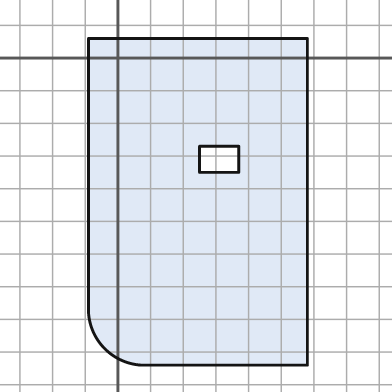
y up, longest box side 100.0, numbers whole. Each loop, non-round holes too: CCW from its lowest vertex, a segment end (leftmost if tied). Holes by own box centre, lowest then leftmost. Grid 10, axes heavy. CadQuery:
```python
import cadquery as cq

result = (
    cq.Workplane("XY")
    .moveTo(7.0, -94.0)
    .lineTo(58.0, -94.0)
    .lineTo(58.0, 6.0)
    .lineTo(-9.0, 6.0)
    .lineTo(-9.0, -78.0)
    .threePointArc((-4.0, -89.0), (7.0, -94.0))
    .close()
    .moveTo(25.0, -35.0)
    .lineTo(37.0, -35.0)
    .lineTo(37.0, -27.0)
    .lineTo(25.0, -27.0)
    .close()
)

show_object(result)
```